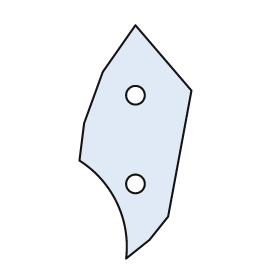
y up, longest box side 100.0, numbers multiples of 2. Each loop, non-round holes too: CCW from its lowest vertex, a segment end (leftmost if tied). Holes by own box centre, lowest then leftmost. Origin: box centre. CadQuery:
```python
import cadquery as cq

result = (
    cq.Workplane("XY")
    .moveTo(-4.0, -50.0)
    .lineTo(6.0, -42.0)
    .lineTo(14.0, -32.0)
    .lineTo(24.0, 22.0)
    .lineTo(0.0, 50.0)
    .lineTo(-14.0, 30.0)
    .lineTo(-22.0, 8.0)
    .lineTo(-24.0, -8.0)
    .threePointArc((-8.0, -26.0), (-4.0, -50.0))
    .close()
    .moveTo(0.0, -18.0)
    .circle(4.0)
    .moveTo(0.0, 20.0)
    .circle(4.0)
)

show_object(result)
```